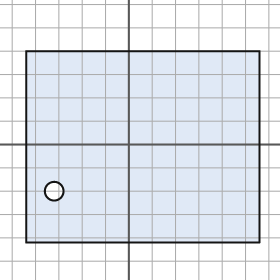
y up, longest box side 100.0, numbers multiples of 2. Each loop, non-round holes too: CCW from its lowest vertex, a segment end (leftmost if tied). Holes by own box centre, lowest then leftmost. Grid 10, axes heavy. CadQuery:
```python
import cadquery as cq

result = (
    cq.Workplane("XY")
    .moveTo(-44.0, -42.0)
    .lineTo(56.0, -42.0)
    .lineTo(56.0, 40.0)
    .lineTo(-44.0, 40.0)
    .close()
    .moveTo(-32.0, -20.0)
    .circle(4.0)
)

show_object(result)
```